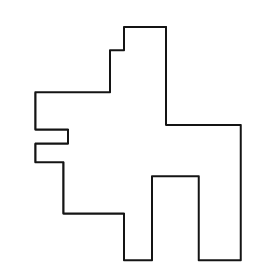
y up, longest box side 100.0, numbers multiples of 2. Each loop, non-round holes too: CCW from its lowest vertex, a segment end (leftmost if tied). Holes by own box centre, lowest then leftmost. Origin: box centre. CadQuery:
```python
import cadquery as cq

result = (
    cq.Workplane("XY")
    .moveTo(-6.0, -50.0)
    .lineTo(6.0, -50.0)
    .lineTo(6.0, -14.0)
    .lineTo(26.0, -14.0)
    .lineTo(26.0, -50.0)
    .lineTo(44.0, -50.0)
    .lineTo(44.0, 8.0)
    .lineTo(12.0, 8.0)
    .lineTo(12.0, 50.0)
    .lineTo(-6.0, 50.0)
    .lineTo(-6.0, 40.0)
    .lineTo(-12.0, 40.0)
    .lineTo(-12.0, 22.0)
    .lineTo(-44.0, 22.0)
    .lineTo(-44.0, 6.0)
    .lineTo(-30.0, 6.0)
    .lineTo(-30.0, 0.0)
    .lineTo(-44.0, 0.0)
    .lineTo(-44.0, -8.0)
    .lineTo(-32.0, -8.0)
    .lineTo(-32.0, -30.0)
    .lineTo(-6.0, -30.0)
    .close()
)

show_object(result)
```